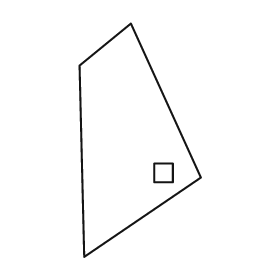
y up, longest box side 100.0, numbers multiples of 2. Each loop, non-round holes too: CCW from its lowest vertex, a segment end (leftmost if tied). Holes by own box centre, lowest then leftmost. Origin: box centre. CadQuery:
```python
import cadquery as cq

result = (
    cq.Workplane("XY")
    .moveTo(-24.0, -50.0)
    .lineTo(26.0, -16.0)
    .lineTo(-4.0, 50.0)
    .lineTo(-26.0, 32.0)
    .close()
    .moveTo(6.0, -18.0)
    .lineTo(14.0, -18.0)
    .lineTo(14.0, -10.0)
    .lineTo(6.0, -10.0)
    .close()
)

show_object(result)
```